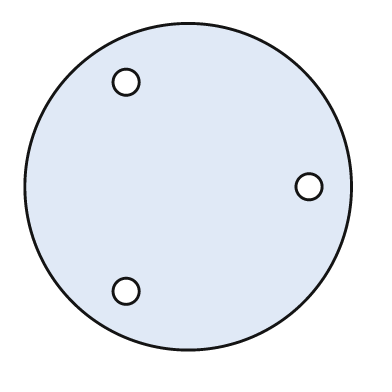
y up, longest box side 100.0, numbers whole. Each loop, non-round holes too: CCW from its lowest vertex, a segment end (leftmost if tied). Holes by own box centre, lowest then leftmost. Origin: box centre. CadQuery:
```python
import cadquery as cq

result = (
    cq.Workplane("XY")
    .moveTo(0.0, 0.0)
    .circle(50.0)
    .moveTo(-19.0, -32.0)
    .circle(4.0)
    .moveTo(37.0, 0.0)
    .circle(4.0)
    .moveTo(-19.0, 32.0)
    .circle(4.0)
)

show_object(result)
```